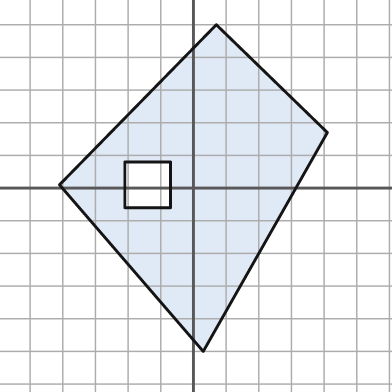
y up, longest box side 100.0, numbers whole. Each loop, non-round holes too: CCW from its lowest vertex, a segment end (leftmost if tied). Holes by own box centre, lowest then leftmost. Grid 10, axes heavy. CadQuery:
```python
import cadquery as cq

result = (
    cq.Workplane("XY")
    .moveTo(3.0, -50.0)
    .lineTo(41.0, 17.0)
    .lineTo(7.0, 50.0)
    .lineTo(-41.0, 1.0)
    .close()
    .moveTo(-21.0, -6.0)
    .lineTo(-7.0, -6.0)
    .lineTo(-7.0, 8.0)
    .lineTo(-21.0, 8.0)
    .close()
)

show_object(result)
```